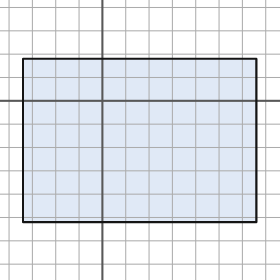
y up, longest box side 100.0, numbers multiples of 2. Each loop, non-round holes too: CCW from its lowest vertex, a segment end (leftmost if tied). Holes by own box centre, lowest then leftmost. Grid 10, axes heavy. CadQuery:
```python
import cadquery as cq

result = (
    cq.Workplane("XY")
    .moveTo(-34.0, -52.0)
    .lineTo(66.0, -52.0)
    .lineTo(66.0, 18.0)
    .lineTo(-34.0, 18.0)
    .close()
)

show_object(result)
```